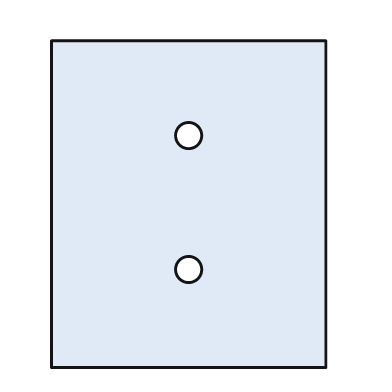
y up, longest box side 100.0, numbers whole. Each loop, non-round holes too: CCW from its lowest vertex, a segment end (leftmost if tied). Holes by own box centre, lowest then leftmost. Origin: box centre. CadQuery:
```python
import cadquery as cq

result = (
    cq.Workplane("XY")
    .moveTo(-42.0, -50.0)
    .lineTo(42.0, -50.0)
    .lineTo(42.0, 50.0)
    .lineTo(-42.0, 50.0)
    .close()
    .moveTo(0.0, -20.0)
    .circle(4.0)
    .moveTo(0.0, 21.0)
    .circle(4.0)
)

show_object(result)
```